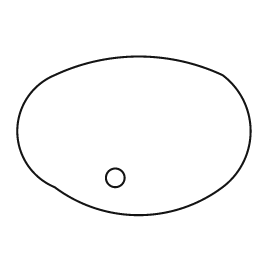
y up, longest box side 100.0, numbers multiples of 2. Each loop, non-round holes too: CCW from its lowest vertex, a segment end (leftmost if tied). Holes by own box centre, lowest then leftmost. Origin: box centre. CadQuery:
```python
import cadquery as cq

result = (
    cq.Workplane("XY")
    .moveTo(-34.0, -22.0)
    .threePointArc((2.0, -34.0), (38.0, -22.0))
    .threePointArc((50.0, 2.0), (38.0, 26.0))
    .threePointArc((2.0, 34.0), (-34.0, 26.0))
    .threePointArc((-50.0, 2.0), (-34.0, -22.0))
    .close()
    .moveTo(-8.0, -18.0)
    .circle(4.0)
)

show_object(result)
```